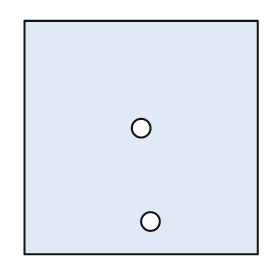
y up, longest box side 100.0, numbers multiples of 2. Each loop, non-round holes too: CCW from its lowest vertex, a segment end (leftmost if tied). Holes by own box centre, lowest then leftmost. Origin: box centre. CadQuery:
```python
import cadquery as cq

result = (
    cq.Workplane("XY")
    .moveTo(-50.0, -50.0)
    .lineTo(50.0, -50.0)
    .lineTo(50.0, 50.0)
    .lineTo(-50.0, 50.0)
    .close()
    .moveTo(4.0, -36.0)
    .circle(4.0)
    .moveTo(0.0, 4.0)
    .circle(4.0)
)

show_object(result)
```